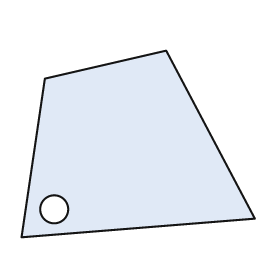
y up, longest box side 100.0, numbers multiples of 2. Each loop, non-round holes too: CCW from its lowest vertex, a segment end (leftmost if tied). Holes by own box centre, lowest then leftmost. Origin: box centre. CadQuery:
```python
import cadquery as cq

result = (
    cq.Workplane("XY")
    .moveTo(-50.0, -40.0)
    .lineTo(50.0, -32.0)
    .lineTo(12.0, 40.0)
    .lineTo(-40.0, 28.0)
    .close()
    .moveTo(-36.0, -28.0)
    .circle(6.0)
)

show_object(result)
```